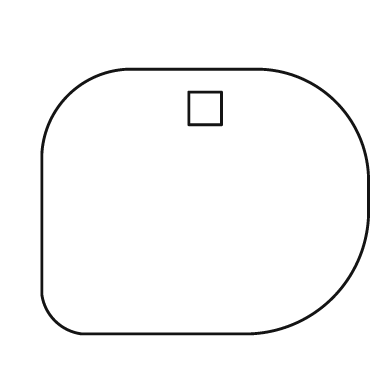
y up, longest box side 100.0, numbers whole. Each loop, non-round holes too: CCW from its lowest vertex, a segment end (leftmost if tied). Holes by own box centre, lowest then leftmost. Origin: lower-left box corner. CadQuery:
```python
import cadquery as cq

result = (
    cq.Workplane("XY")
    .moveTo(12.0, 0.0)
    .lineTo(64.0, 0.0)
    .threePointArc((89.0, 11.0), (100.0, 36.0))
    .lineTo(100.0, 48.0)
    .threePointArc((90.0, 71.0), (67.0, 81.0))
    .lineTo(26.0, 81.0)
    .threePointArc((8.0, 73.0), (0.0, 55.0))
    .lineTo(0.0, 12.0)
    .threePointArc((4.0, 4.0), (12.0, 0.0))
    .close()
    .moveTo(45.0, 64.0)
    .lineTo(55.0, 64.0)
    .lineTo(55.0, 74.0)
    .lineTo(45.0, 74.0)
    .close()
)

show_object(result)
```